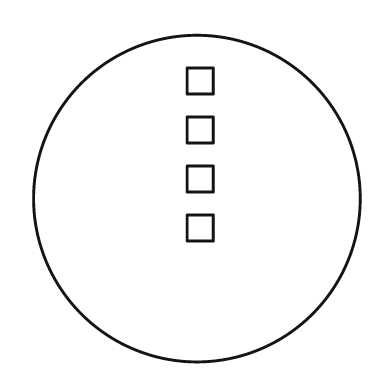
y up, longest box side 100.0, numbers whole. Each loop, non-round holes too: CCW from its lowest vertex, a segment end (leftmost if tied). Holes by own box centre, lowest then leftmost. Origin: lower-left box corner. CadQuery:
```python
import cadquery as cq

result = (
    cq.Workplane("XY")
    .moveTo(50.0, 50.0)
    .circle(50.0)
    .moveTo(47.0, 37.0)
    .lineTo(55.0, 37.0)
    .lineTo(55.0, 45.0)
    .lineTo(47.0, 45.0)
    .close()
    .moveTo(47.0, 52.0)
    .lineTo(55.0, 52.0)
    .lineTo(55.0, 60.0)
    .lineTo(47.0, 60.0)
    .close()
    .moveTo(47.0, 67.0)
    .lineTo(55.0, 67.0)
    .lineTo(55.0, 75.0)
    .lineTo(47.0, 75.0)
    .close()
    .moveTo(47.0, 82.0)
    .lineTo(55.0, 82.0)
    .lineTo(55.0, 90.0)
    .lineTo(47.0, 90.0)
    .close()
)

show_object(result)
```